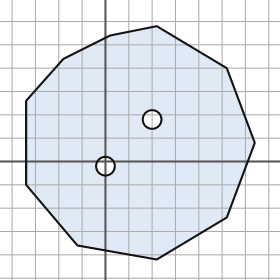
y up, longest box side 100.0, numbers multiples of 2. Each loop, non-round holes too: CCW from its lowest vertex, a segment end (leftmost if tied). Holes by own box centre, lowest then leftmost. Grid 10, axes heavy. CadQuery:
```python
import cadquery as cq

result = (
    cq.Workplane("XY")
    .moveTo(22.0, -42.0)
    .lineTo(52.0, -24.0)
    .lineTo(64.0, 8.0)
    .lineTo(52.0, 40.0)
    .lineTo(22.0, 58.0)
    .lineTo(2.0, 54.0)
    .lineTo(-18.0, 44.0)
    .lineTo(-34.0, 26.0)
    .lineTo(-34.0, -10.0)
    .lineTo(-12.0, -36.0)
    .close()
    .moveTo(0.0, -2.0)
    .circle(4.0)
    .moveTo(20.0, 18.0)
    .circle(4.0)
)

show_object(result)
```